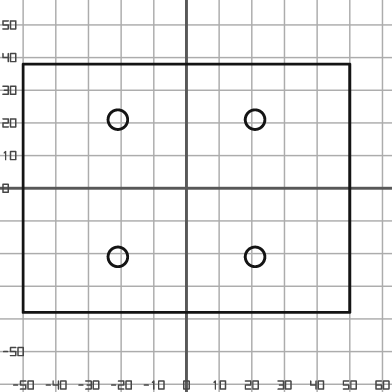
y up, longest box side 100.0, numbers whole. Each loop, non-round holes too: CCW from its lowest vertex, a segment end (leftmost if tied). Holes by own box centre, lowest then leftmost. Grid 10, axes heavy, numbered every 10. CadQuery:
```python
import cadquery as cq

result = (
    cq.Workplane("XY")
    .moveTo(-50.0, -38.0)
    .lineTo(50.0, -38.0)
    .lineTo(50.0, 38.0)
    .lineTo(-50.0, 38.0)
    .close()
    .moveTo(-21.0, -21.0)
    .circle(3.0)
    .moveTo(21.0, -21.0)
    .circle(3.0)
    .moveTo(-21.0, 21.0)
    .circle(3.0)
    .moveTo(21.0, 21.0)
    .circle(3.0)
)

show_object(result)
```